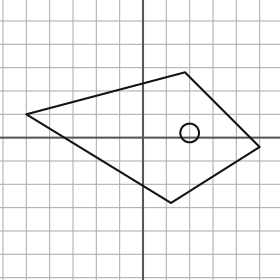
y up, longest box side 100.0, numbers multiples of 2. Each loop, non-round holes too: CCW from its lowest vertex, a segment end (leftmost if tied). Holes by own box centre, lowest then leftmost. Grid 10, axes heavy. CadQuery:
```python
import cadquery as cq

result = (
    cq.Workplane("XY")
    .moveTo(12.0, -28.0)
    .lineTo(50.0, -4.0)
    .lineTo(18.0, 28.0)
    .lineTo(-50.0, 10.0)
    .close()
    .moveTo(20.0, 2.0)
    .circle(4.0)
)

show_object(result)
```